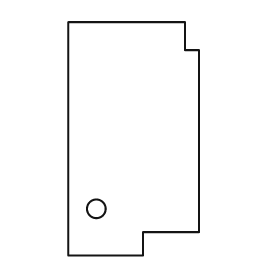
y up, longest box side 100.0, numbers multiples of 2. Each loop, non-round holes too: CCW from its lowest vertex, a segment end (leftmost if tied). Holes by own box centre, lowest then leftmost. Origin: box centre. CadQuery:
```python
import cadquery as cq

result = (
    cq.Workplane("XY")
    .moveTo(-28.0, -50.0)
    .lineTo(4.0, -50.0)
    .lineTo(4.0, -40.0)
    .lineTo(28.0, -40.0)
    .lineTo(28.0, 38.0)
    .lineTo(22.0, 38.0)
    .lineTo(22.0, 50.0)
    .lineTo(-28.0, 50.0)
    .close()
    .moveTo(-16.0, -30.0)
    .circle(4.0)
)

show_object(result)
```